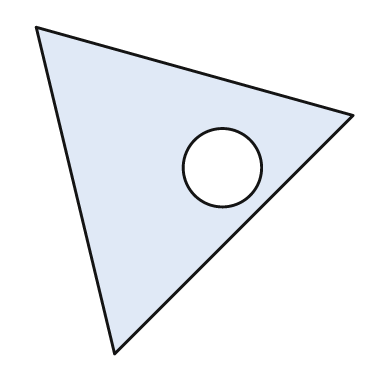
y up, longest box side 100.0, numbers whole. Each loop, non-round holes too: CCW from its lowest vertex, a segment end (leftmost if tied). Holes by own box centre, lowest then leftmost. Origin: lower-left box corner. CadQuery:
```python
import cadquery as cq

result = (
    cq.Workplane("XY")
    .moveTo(24.0, 0.0)
    .lineTo(97.0, 73.0)
    .lineTo(0.0, 100.0)
    .close()
    .moveTo(57.0, 57.0)
    .circle(12.0)
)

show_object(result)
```